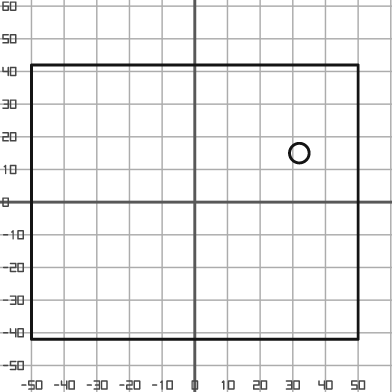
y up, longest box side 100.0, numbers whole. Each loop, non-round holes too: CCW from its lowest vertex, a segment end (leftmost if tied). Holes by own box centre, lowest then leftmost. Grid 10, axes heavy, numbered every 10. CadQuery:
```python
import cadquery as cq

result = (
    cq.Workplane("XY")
    .moveTo(-50.0, -42.0)
    .lineTo(50.0, -42.0)
    .lineTo(50.0, 42.0)
    .lineTo(-50.0, 42.0)
    .close()
    .moveTo(32.0, 15.0)
    .circle(3.0)
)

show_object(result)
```